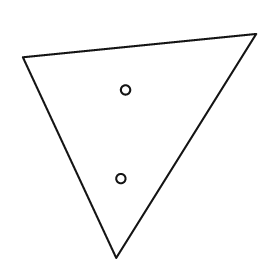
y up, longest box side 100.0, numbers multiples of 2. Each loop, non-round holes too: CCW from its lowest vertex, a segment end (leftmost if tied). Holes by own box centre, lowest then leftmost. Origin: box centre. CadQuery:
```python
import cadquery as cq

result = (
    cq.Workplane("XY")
    .moveTo(-10.0, -48.0)
    .lineTo(50.0, 48.0)
    .lineTo(-50.0, 38.0)
    .close()
    .moveTo(-8.0, -14.0)
    .circle(2.0)
    .moveTo(-6.0, 24.0)
    .circle(2.0)
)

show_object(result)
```